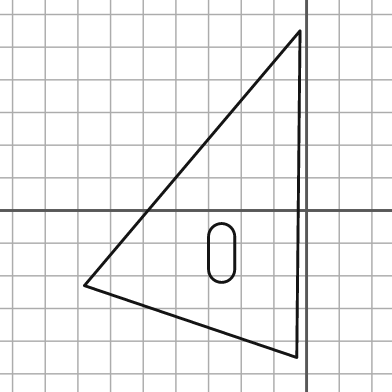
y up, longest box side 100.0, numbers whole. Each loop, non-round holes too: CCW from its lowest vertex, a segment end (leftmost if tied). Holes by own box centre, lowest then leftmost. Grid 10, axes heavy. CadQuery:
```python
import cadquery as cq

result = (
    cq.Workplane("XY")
    .moveTo(-3.0, -45.0)
    .lineTo(-2.0, 55.0)
    .lineTo(-68.0, -23.0)
    .close()
    .moveTo(-30.0, -18.0)
    .threePointArc((-26.0, -22.0), (-22.0, -18.0))
    .lineTo(-22.0, -8.0)
    .threePointArc((-26.0, -4.0), (-30.0, -8.0))
    .close()
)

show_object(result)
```